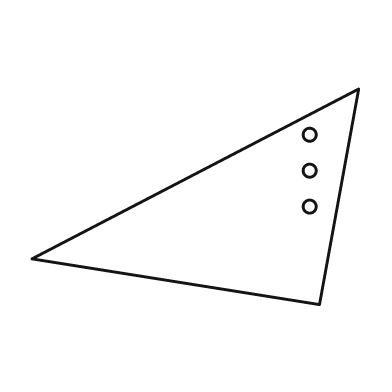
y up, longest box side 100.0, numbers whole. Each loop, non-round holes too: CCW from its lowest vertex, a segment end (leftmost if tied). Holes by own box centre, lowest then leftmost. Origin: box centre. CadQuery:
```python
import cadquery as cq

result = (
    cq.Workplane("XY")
    .moveTo(38.0, -33.0)
    .lineTo(50.0, 33.0)
    .lineTo(-50.0, -19.0)
    .close()
    .moveTo(35.0, -3.0)
    .circle(2.0)
    .moveTo(35.0, 8.0)
    .circle(2.0)
    .moveTo(35.0, 19.0)
    .circle(2.0)
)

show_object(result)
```